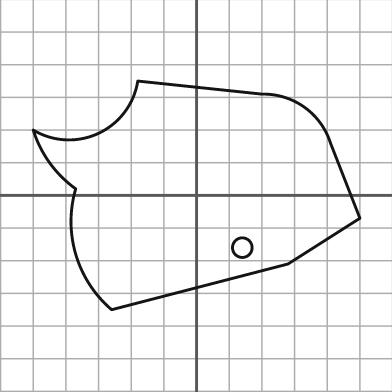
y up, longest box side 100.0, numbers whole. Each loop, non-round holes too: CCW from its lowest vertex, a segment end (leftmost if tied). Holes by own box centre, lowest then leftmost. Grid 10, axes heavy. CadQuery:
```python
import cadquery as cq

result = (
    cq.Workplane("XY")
    .moveTo(-26.0, -35.0)
    .lineTo(28.0, -21.0)
    .lineTo(50.0, -7.0)
    .lineTo(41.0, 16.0)
    .threePointArc((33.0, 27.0), (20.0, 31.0))
    .lineTo(-18.0, 35.0)
    .threePointArc((-30.0, 19.0), (-50.0, 20.0))
    .threePointArc((-45.0, 10.0), (-37.0, 2.0))
    .threePointArc((-37.0, -18.0), (-26.0, -35.0))
    .close()
    .moveTo(14.0, -16.0)
    .circle(3.0)
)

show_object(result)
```